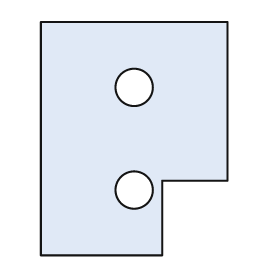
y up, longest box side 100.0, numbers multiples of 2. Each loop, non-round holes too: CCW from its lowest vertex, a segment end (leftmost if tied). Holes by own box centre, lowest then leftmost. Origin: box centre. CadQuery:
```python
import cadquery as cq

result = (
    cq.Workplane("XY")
    .moveTo(-40.0, -50.0)
    .lineTo(12.0, -50.0)
    .lineTo(12.0, -18.0)
    .lineTo(40.0, -18.0)
    .lineTo(40.0, 50.0)
    .lineTo(-40.0, 50.0)
    .close()
    .moveTo(0.0, -22.0)
    .circle(8.0)
    .moveTo(0.0, 22.0)
    .circle(8.0)
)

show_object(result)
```